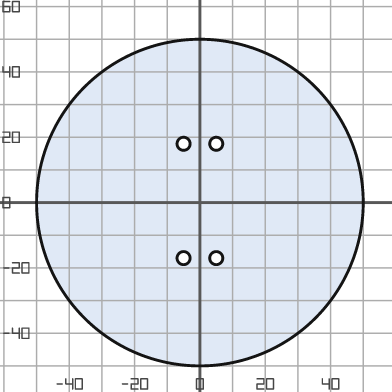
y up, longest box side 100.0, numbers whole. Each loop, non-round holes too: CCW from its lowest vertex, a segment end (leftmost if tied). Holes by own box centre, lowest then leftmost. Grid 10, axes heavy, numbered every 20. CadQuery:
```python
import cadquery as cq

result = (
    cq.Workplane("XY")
    .moveTo(0.0, 0.0)
    .circle(50.0)
    .moveTo(-5.0, -17.0)
    .circle(2.0)
    .moveTo(5.0, -17.0)
    .circle(2.0)
    .moveTo(-5.0, 18.0)
    .circle(2.0)
    .moveTo(5.0, 18.0)
    .circle(2.0)
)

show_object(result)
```